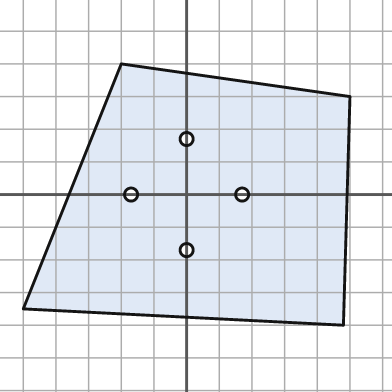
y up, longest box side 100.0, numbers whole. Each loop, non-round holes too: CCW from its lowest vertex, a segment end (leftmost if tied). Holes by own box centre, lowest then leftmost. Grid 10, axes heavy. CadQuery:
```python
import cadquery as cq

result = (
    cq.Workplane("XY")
    .moveTo(48.0, -40.0)
    .lineTo(50.0, 30.0)
    .lineTo(-20.0, 40.0)
    .lineTo(-50.0, -35.0)
    .close()
    .moveTo(0.0, -17.0)
    .circle(2.0)
    .moveTo(-17.0, 0.0)
    .circle(2.0)
    .moveTo(17.0, 0.0)
    .circle(2.0)
    .moveTo(0.0, 17.0)
    .circle(2.0)
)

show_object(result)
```